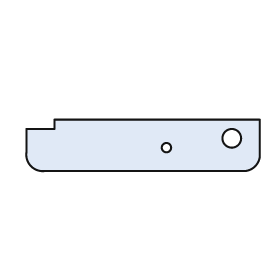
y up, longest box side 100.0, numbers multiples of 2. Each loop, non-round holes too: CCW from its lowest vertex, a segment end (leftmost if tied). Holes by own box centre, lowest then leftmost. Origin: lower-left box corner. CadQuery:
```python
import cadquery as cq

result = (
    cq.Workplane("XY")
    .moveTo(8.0, 0.0)
    .lineTo(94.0, 0.0)
    .threePointArc((98.0, 2.0), (100.0, 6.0))
    .lineTo(100.0, 22.0)
    .lineTo(12.0, 22.0)
    .lineTo(12.0, 18.0)
    .lineTo(0.0, 18.0)
    .lineTo(0.0, 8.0)
    .threePointArc((2.0, 2.0), (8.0, 0.0))
    .close()
    .moveTo(60.0, 10.0)
    .circle(2.0)
    .moveTo(88.0, 14.0)
    .circle(4.0)
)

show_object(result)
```